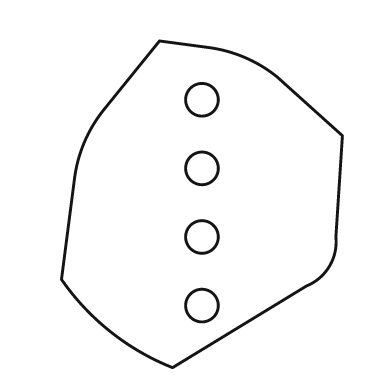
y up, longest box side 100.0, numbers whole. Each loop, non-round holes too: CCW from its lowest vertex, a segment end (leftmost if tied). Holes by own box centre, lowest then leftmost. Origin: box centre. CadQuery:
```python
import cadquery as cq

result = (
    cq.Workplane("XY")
    .moveTo(-9.0, -50.0)
    .lineTo(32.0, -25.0)
    .threePointArc((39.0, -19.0), (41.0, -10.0))
    .lineTo(43.0, 21.0)
    .lineTo(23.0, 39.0)
    .threePointArc((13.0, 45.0), (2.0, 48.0))
    .lineTo(-13.0, 50.0)
    .lineTo(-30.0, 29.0)
    .threePointArc((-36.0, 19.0), (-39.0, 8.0))
    .lineTo(-43.0, -23.0)
    .threePointArc((-28.0, -39.0), (-9.0, -50.0))
    .close()
    .moveTo(0.0, -31.0)
    .circle(5.0)
    .moveTo(0.0, -10.0)
    .circle(5.0)
    .moveTo(0.0, 11.0)
    .circle(5.0)
    .moveTo(0.0, 32.0)
    .circle(5.0)
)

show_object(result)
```